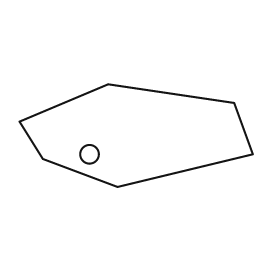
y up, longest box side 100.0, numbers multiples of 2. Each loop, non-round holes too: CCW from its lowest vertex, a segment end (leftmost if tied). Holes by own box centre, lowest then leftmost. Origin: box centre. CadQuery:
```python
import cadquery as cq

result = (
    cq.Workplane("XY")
    .moveTo(-8.0, -22.0)
    .lineTo(50.0, -8.0)
    .lineTo(42.0, 14.0)
    .lineTo(-12.0, 22.0)
    .lineTo(-50.0, 6.0)
    .lineTo(-40.0, -10.0)
    .close()
    .moveTo(-20.0, -8.0)
    .circle(4.0)
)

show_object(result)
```